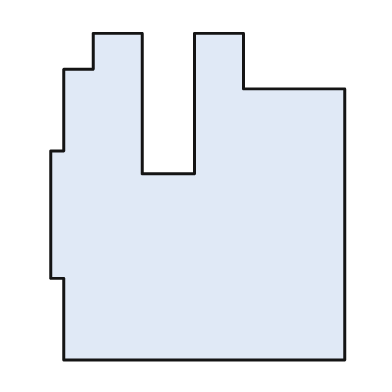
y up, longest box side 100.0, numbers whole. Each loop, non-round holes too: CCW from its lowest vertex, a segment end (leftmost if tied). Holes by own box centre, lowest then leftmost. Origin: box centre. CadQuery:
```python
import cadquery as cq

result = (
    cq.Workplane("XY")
    .moveTo(-41.0, -50.0)
    .lineTo(45.0, -50.0)
    .lineTo(45.0, 33.0)
    .lineTo(14.0, 33.0)
    .lineTo(14.0, 50.0)
    .lineTo(-1.0, 50.0)
    .lineTo(-1.0, 7.0)
    .lineTo(-17.0, 7.0)
    .lineTo(-17.0, 50.0)
    .lineTo(-32.0, 50.0)
    .lineTo(-32.0, 39.0)
    .lineTo(-41.0, 39.0)
    .lineTo(-41.0, 14.0)
    .lineTo(-45.0, 14.0)
    .lineTo(-45.0, -25.0)
    .lineTo(-41.0, -25.0)
    .close()
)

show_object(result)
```